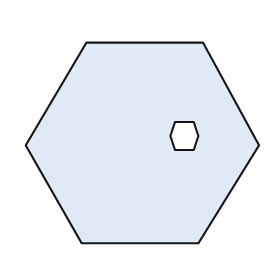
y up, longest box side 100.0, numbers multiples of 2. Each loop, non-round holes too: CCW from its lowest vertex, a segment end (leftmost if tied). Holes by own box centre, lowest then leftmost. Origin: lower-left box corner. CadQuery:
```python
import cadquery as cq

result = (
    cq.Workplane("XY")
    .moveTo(24.0, 0.0)
    .lineTo(74.0, 0.0)
    .lineTo(100.0, 42.0)
    .lineTo(76.0, 86.0)
    .lineTo(26.0, 86.0)
    .lineTo(0.0, 42.0)
    .close()
    .moveTo(64.0, 40.0)
    .lineTo(72.0, 40.0)
    .lineTo(74.0, 46.0)
    .lineTo(72.0, 52.0)
    .lineTo(64.0, 52.0)
    .lineTo(62.0, 46.0)
    .close()
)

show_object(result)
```